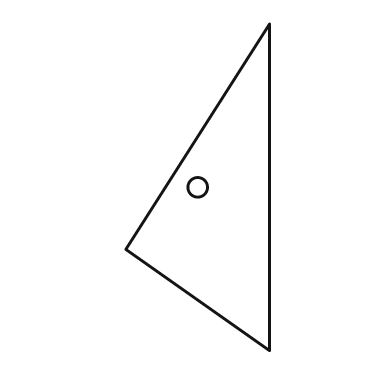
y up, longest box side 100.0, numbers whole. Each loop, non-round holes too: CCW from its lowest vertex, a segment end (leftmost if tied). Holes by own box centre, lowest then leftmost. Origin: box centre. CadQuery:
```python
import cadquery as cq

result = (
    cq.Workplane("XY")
    .moveTo(22.0, -50.0)
    .lineTo(22.0, 50.0)
    .lineTo(-22.0, -19.0)
    .close()
    .moveTo(0.0, 0.0)
    .circle(3.0)
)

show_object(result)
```